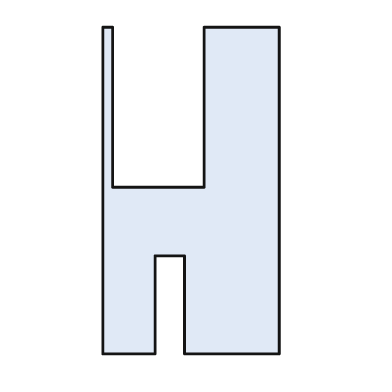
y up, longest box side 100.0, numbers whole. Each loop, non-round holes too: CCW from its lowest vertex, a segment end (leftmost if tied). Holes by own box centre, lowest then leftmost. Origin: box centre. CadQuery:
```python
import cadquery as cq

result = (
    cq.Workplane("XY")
    .moveTo(-27.0, -50.0)
    .lineTo(-11.0, -50.0)
    .lineTo(-11.0, -20.0)
    .lineTo(-2.0, -20.0)
    .lineTo(-2.0, -50.0)
    .lineTo(27.0, -50.0)
    .lineTo(27.0, 50.0)
    .lineTo(4.0, 50.0)
    .lineTo(4.0, 1.0)
    .lineTo(-24.0, 1.0)
    .lineTo(-24.0, 50.0)
    .lineTo(-27.0, 50.0)
    .close()
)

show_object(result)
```